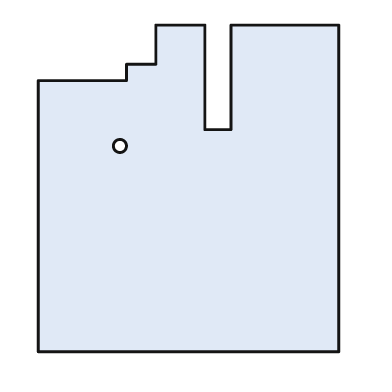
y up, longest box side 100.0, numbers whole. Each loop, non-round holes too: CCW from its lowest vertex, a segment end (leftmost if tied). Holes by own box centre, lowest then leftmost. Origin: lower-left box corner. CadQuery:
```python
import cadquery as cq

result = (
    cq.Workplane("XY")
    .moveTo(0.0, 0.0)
    .lineTo(92.0, 0.0)
    .lineTo(92.0, 100.0)
    .lineTo(59.0, 100.0)
    .lineTo(59.0, 68.0)
    .lineTo(51.0, 68.0)
    .lineTo(51.0, 100.0)
    .lineTo(36.0, 100.0)
    .lineTo(36.0, 88.0)
    .lineTo(27.0, 88.0)
    .lineTo(27.0, 83.0)
    .lineTo(0.0, 83.0)
    .close()
    .moveTo(25.0, 63.0)
    .circle(2.0)
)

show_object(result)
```